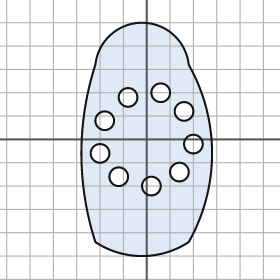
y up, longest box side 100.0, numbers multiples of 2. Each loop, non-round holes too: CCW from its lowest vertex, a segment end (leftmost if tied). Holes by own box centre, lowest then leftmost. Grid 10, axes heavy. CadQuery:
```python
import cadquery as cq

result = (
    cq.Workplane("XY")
    .moveTo(-22.0, -44.0)
    .threePointArc((-2.0, -50.0), (18.0, -44.0))
    .threePointArc((28.0, -6.0), (18.0, 32.0))
    .threePointArc((-2.0, 50.0), (-22.0, 32.0))
    .threePointArc((-28.0, -6.0), (-22.0, -44.0))
    .close()
    .moveTo(2.0, -20.0)
    .circle(4.0)
    .moveTo(-12.0, -16.0)
    .circle(4.0)
    .moveTo(14.0, -14.0)
    .circle(4.0)
    .moveTo(-20.0, -6.0)
    .circle(4.0)
    .moveTo(20.0, -2.0)
    .circle(4.0)
    .moveTo(-18.0, 8.0)
    .circle(4.0)
    .moveTo(16.0, 12.0)
    .circle(4.0)
    .moveTo(-8.0, 18.0)
    .circle(4.0)
    .moveTo(6.0, 20.0)
    .circle(4.0)
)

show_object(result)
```